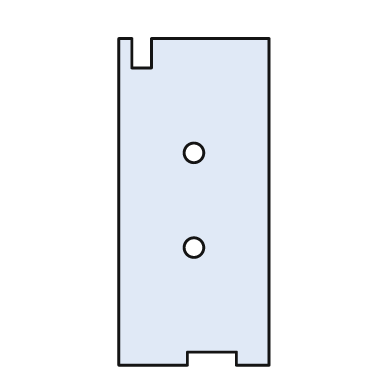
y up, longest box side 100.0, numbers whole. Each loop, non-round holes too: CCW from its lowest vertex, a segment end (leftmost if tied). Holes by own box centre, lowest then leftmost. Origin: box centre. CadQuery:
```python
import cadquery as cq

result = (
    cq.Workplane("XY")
    .moveTo(-23.0, -50.0)
    .lineTo(-2.0, -50.0)
    .lineTo(-2.0, -46.0)
    .lineTo(13.0, -46.0)
    .lineTo(13.0, -50.0)
    .lineTo(23.0, -50.0)
    .lineTo(23.0, 50.0)
    .lineTo(-13.0, 50.0)
    .lineTo(-13.0, 41.0)
    .lineTo(-19.0, 41.0)
    .lineTo(-19.0, 50.0)
    .lineTo(-23.0, 50.0)
    .close()
    .moveTo(0.0, -14.0)
    .circle(3.0)
    .moveTo(0.0, 15.0)
    .circle(3.0)
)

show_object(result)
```